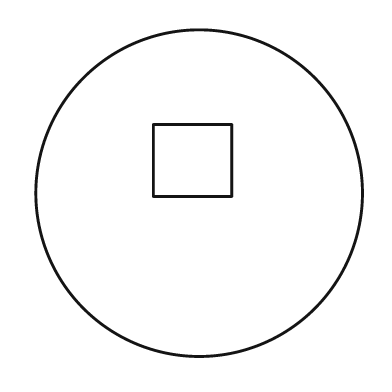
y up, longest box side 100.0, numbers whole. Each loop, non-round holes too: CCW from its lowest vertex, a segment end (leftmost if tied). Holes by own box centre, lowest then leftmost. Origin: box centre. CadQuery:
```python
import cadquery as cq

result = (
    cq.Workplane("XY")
    .moveTo(0.0, 0.0)
    .circle(50.0)
    .moveTo(-14.0, -1.0)
    .lineTo(10.0, -1.0)
    .lineTo(10.0, 21.0)
    .lineTo(-14.0, 21.0)
    .close()
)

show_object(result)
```